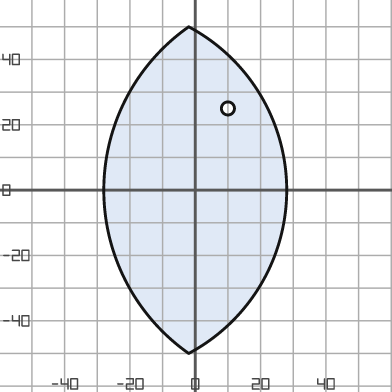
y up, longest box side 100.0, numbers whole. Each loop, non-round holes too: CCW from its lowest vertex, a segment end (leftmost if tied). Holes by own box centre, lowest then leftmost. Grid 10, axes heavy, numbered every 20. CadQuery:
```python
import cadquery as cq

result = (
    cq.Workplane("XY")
    .moveTo(-2.0, -50.0)
    .threePointArc((28.0, 0.0), (-2.0, 50.0))
    .threePointArc((-28.0, 0.0), (-2.0, -50.0))
    .close()
    .moveTo(10.0, 25.0)
    .circle(2.0)
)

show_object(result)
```